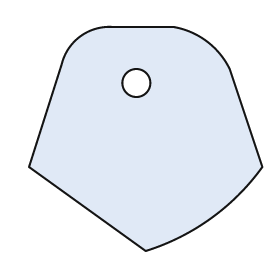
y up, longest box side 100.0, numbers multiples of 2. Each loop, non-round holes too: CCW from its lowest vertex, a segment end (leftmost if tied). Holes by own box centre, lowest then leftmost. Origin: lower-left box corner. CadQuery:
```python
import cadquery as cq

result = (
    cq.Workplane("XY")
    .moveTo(50.0, 0.0)
    .threePointArc((78.0, 14.0), (100.0, 36.0))
    .lineTo(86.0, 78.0)
    .threePointArc((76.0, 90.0), (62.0, 96.0))
    .lineTo(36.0, 96.0)
    .threePointArc((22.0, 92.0), (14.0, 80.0))
    .lineTo(0.0, 36.0)
    .close()
    .moveTo(46.0, 72.0)
    .circle(6.0)
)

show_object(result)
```